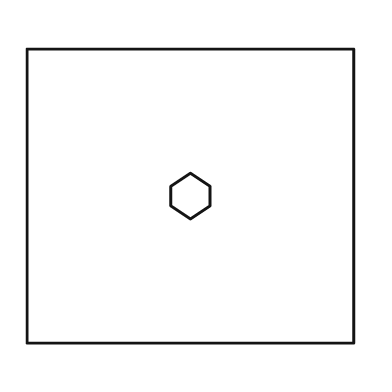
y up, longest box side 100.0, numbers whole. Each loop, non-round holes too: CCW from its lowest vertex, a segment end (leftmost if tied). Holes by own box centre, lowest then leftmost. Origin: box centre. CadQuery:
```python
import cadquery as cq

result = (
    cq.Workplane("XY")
    .moveTo(-50.0, -45.0)
    .lineTo(50.0, -45.0)
    .lineTo(50.0, 45.0)
    .lineTo(-50.0, 45.0)
    .close()
    .moveTo(0.0, -7.0)
    .lineTo(6.0, -3.0)
    .lineTo(6.0, 3.0)
    .lineTo(0.0, 7.0)
    .lineTo(-6.0, 3.0)
    .lineTo(-6.0, -3.0)
    .close()
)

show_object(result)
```